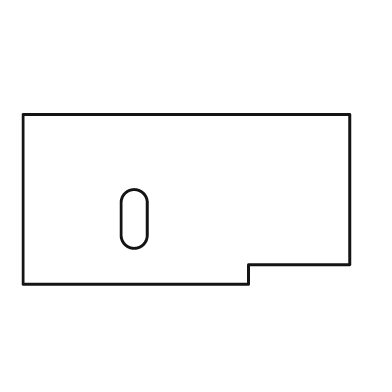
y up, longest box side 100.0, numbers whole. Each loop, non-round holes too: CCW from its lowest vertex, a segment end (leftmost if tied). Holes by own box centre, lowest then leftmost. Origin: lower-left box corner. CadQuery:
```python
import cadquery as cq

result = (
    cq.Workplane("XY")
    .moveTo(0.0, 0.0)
    .lineTo(69.0, 0.0)
    .lineTo(69.0, 6.0)
    .lineTo(100.0, 6.0)
    .lineTo(100.0, 52.0)
    .lineTo(0.0, 52.0)
    .close()
    .moveTo(30.0, 15.0)
    .threePointArc((34.0, 11.0), (38.0, 15.0))
    .lineTo(38.0, 25.0)
    .threePointArc((34.0, 29.0), (30.0, 25.0))
    .close()
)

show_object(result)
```